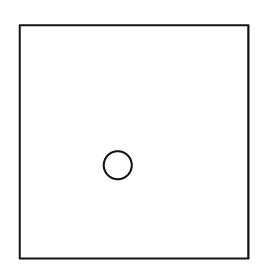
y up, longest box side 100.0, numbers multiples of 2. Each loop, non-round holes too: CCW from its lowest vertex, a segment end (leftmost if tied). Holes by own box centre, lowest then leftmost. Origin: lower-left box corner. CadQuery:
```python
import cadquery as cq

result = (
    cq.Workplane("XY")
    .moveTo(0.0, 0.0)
    .lineTo(98.0, 0.0)
    .lineTo(98.0, 100.0)
    .lineTo(0.0, 100.0)
    .close()
    .moveTo(42.0, 40.0)
    .circle(6.0)
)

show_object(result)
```